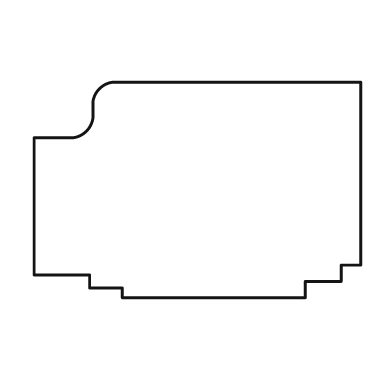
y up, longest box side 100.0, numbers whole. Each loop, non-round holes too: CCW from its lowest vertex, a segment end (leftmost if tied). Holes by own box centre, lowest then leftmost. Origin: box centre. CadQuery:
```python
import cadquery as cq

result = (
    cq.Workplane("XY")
    .moveTo(-23.0, -33.0)
    .lineTo(33.0, -33.0)
    .lineTo(33.0, -28.0)
    .lineTo(44.0, -28.0)
    .lineTo(44.0, -23.0)
    .lineTo(50.0, -23.0)
    .lineTo(50.0, 33.0)
    .lineTo(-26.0, 33.0)
    .threePointArc((-30.0, 31.0), (-32.0, 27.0))
    .lineTo(-32.0, 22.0)
    .threePointArc((-34.0, 18.0), (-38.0, 16.0))
    .lineTo(-50.0, 16.0)
    .lineTo(-50.0, -26.0)
    .lineTo(-33.0, -26.0)
    .lineTo(-33.0, -30.0)
    .lineTo(-23.0, -30.0)
    .close()
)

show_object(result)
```